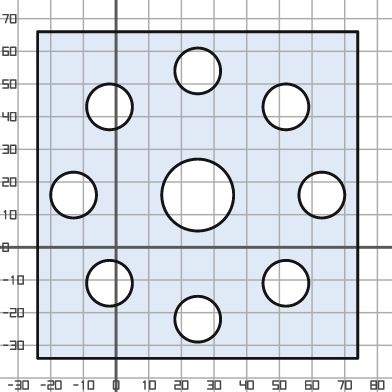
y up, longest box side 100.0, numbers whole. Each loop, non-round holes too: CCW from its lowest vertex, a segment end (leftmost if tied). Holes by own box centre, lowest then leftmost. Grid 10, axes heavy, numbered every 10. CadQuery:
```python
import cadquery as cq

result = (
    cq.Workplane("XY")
    .moveTo(-24.0, -34.0)
    .lineTo(74.0, -34.0)
    .lineTo(74.0, 66.0)
    .lineTo(-24.0, 66.0)
    .close()
    .moveTo(25.0, -22.0)
    .circle(7.0)
    .moveTo(-2.0, -11.0)
    .circle(7.0)
    .moveTo(52.0, -11.0)
    .circle(7.0)
    .moveTo(-13.0, 16.0)
    .circle(7.0)
    .moveTo(25.0, 16.0)
    .circle(11.0)
    .moveTo(63.0, 16.0)
    .circle(7.0)
    .moveTo(-2.0, 43.0)
    .circle(7.0)
    .moveTo(52.0, 43.0)
    .circle(7.0)
    .moveTo(25.0, 54.0)
    .circle(7.0)
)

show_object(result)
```